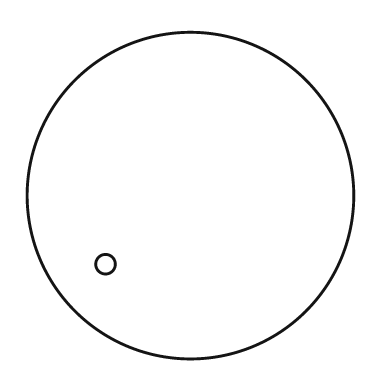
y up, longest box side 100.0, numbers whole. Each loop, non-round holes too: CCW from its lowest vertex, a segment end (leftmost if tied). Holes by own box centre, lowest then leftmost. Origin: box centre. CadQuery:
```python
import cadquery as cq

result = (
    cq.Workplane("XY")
    .moveTo(0.0, 0.0)
    .circle(50.0)
    .moveTo(-26.0, -21.0)
    .circle(3.0)
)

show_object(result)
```